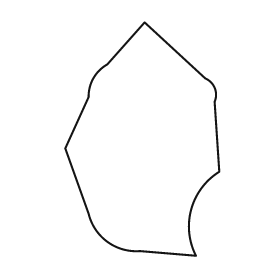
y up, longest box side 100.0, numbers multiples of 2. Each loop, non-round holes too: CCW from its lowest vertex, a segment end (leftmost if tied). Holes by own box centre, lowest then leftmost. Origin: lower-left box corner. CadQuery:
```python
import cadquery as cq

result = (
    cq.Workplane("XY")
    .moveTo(56.0, 0.0)
    .threePointArc((54.0, 20.0), (66.0, 36.0))
    .lineTo(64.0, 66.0)
    .threePointArc((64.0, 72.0), (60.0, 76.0))
    .lineTo(34.0, 100.0)
    .lineTo(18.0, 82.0)
    .threePointArc((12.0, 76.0), (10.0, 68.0))
    .lineTo(0.0, 46.0)
    .lineTo(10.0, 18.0)
    .threePointArc((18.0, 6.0), (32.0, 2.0))
    .close()
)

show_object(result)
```